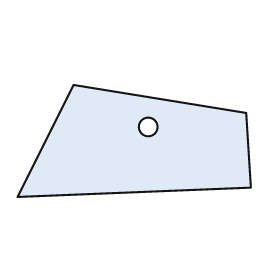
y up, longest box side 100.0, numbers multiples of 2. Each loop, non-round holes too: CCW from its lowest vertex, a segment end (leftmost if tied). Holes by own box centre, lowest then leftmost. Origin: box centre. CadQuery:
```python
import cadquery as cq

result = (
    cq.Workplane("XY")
    .moveTo(-50.0, -24.0)
    .lineTo(50.0, -20.0)
    .lineTo(48.0, 12.0)
    .lineTo(-26.0, 24.0)
    .close()
    .moveTo(6.0, 6.0)
    .circle(4.0)
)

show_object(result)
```